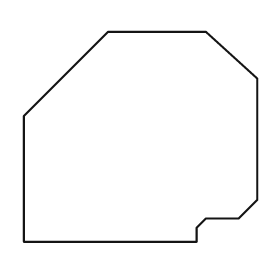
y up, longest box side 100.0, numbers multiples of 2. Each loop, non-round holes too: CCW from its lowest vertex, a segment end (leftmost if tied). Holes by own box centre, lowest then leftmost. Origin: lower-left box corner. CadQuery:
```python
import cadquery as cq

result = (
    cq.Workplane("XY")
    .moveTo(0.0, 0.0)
    .lineTo(74.0, 0.0)
    .lineTo(74.0, 6.0)
    .lineTo(78.0, 10.0)
    .lineTo(92.0, 10.0)
    .lineTo(100.0, 18.0)
    .lineTo(100.0, 70.0)
    .lineTo(78.0, 90.0)
    .lineTo(36.0, 90.0)
    .lineTo(0.0, 54.0)
    .close()
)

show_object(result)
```